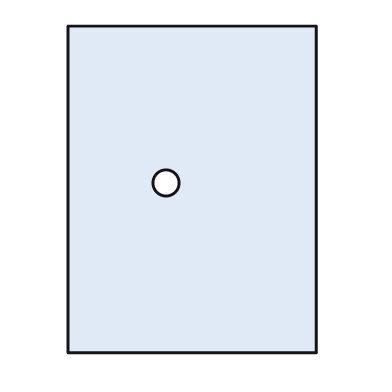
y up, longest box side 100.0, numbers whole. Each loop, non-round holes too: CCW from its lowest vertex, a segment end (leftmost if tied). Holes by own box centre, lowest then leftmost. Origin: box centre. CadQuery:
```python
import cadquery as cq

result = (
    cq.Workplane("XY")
    .moveTo(-38.0, -50.0)
    .lineTo(38.0, -50.0)
    .lineTo(38.0, 50.0)
    .lineTo(-38.0, 50.0)
    .close()
    .moveTo(-8.0, 2.0)
    .circle(4.0)
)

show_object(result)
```